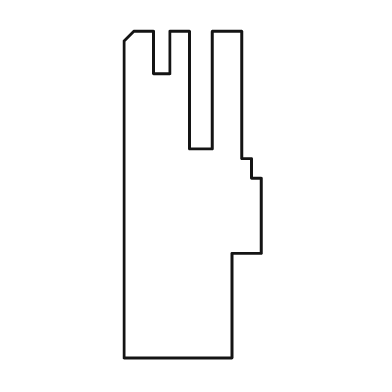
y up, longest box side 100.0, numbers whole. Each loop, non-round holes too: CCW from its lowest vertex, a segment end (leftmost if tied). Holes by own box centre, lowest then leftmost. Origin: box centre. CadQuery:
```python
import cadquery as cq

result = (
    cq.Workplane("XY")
    .moveTo(-21.0, -50.0)
    .lineTo(12.0, -50.0)
    .lineTo(12.0, -18.0)
    .lineTo(21.0, -18.0)
    .lineTo(21.0, 5.0)
    .lineTo(18.0, 5.0)
    .lineTo(18.0, 11.0)
    .lineTo(15.0, 11.0)
    .lineTo(15.0, 50.0)
    .lineTo(6.0, 50.0)
    .lineTo(6.0, 14.0)
    .lineTo(-1.0, 14.0)
    .lineTo(-1.0, 50.0)
    .lineTo(-7.0, 50.0)
    .lineTo(-7.0, 37.0)
    .lineTo(-12.0, 37.0)
    .lineTo(-12.0, 50.0)
    .lineTo(-18.0, 50.0)
    .lineTo(-21.0, 47.0)
    .close()
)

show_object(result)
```